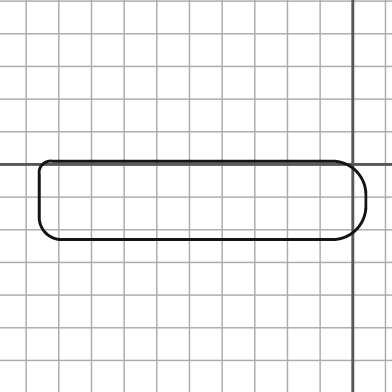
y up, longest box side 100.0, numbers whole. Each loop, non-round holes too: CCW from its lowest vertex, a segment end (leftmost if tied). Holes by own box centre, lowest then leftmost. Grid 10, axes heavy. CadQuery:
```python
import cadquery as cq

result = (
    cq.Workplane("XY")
    .moveTo(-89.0, -23.0)
    .lineTo(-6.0, -23.0)
    .threePointArc((1.0, -20.0), (4.0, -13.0))
    .lineTo(4.0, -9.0)
    .threePointArc((1.0, -2.0), (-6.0, 1.0))
    .lineTo(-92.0, 1.0)
    .threePointArc((-95.0, 0.0), (-96.0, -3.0))
    .lineTo(-96.0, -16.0)
    .threePointArc((-94.0, -21.0), (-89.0, -23.0))
    .close()
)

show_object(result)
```